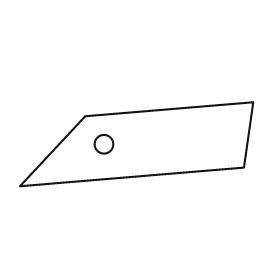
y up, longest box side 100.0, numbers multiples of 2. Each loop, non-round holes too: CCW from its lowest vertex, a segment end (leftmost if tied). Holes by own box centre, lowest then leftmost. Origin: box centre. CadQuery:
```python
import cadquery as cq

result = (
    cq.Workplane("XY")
    .moveTo(-50.0, -18.0)
    .lineTo(46.0, -10.0)
    .lineTo(50.0, 18.0)
    .lineTo(-22.0, 12.0)
    .close()
    .moveTo(-14.0, 0.0)
    .circle(4.0)
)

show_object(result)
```